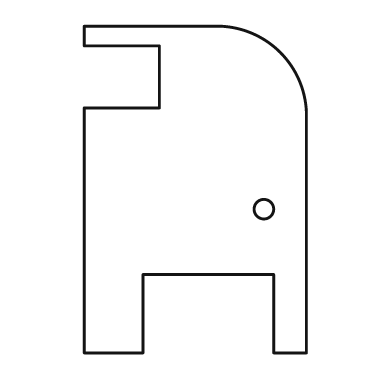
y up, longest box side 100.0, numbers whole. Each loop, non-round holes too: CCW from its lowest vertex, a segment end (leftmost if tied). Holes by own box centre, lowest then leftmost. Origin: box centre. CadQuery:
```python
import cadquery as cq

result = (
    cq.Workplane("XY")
    .moveTo(-34.0, -50.0)
    .lineTo(-16.0, -50.0)
    .lineTo(-16.0, -26.0)
    .lineTo(24.0, -26.0)
    .lineTo(24.0, -50.0)
    .lineTo(34.0, -50.0)
    .lineTo(34.0, 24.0)
    .threePointArc((26.0, 42.0), (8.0, 50.0))
    .lineTo(-34.0, 50.0)
    .lineTo(-34.0, 44.0)
    .lineTo(-11.0, 44.0)
    .lineTo(-11.0, 25.0)
    .lineTo(-34.0, 25.0)
    .close()
    .moveTo(21.0, -6.0)
    .circle(3.0)
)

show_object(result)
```